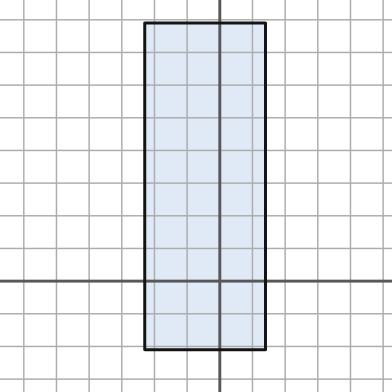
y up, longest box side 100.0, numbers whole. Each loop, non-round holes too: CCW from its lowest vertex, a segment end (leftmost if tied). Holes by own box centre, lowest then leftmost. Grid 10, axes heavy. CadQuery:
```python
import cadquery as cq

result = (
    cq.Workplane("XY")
    .moveTo(-23.0, -21.0)
    .lineTo(14.0, -21.0)
    .lineTo(14.0, 79.0)
    .lineTo(-23.0, 79.0)
    .close()
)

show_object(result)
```